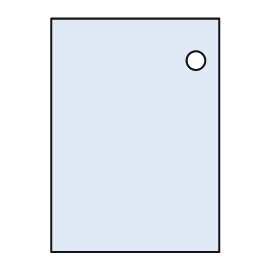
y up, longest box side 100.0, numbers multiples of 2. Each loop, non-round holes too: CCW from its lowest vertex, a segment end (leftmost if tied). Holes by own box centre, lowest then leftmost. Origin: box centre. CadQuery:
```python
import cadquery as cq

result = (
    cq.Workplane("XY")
    .moveTo(-36.0, -50.0)
    .lineTo(36.0, -50.0)
    .lineTo(36.0, 50.0)
    .lineTo(-36.0, 50.0)
    .close()
    .moveTo(26.0, 32.0)
    .circle(4.0)
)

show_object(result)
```